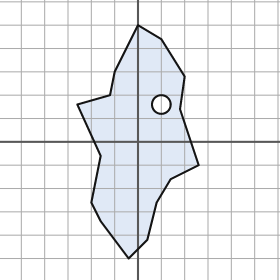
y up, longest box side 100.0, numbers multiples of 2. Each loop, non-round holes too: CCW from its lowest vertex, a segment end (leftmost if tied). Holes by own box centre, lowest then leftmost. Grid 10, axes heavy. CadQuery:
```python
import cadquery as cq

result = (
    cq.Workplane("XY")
    .moveTo(-4.0, -50.0)
    .lineTo(4.0, -42.0)
    .lineTo(8.0, -26.0)
    .lineTo(14.0, -16.0)
    .lineTo(26.0, -10.0)
    .lineTo(18.0, 14.0)
    .lineTo(20.0, 28.0)
    .lineTo(10.0, 44.0)
    .lineTo(0.0, 50.0)
    .lineTo(-10.0, 30.0)
    .lineTo(-12.0, 20.0)
    .lineTo(-26.0, 16.0)
    .lineTo(-16.0, -6.0)
    .lineTo(-20.0, -26.0)
    .lineTo(-16.0, -34.0)
    .close()
    .moveTo(10.0, 16.0)
    .circle(4.0)
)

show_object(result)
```